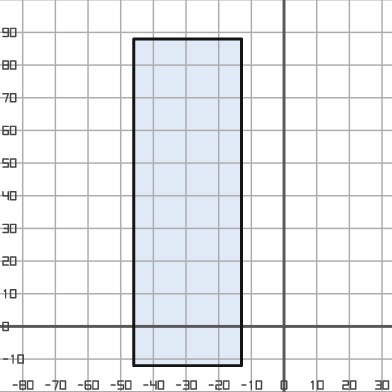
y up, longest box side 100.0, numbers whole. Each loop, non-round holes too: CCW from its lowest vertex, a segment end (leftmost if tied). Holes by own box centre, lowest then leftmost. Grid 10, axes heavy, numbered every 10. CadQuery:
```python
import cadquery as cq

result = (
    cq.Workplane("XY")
    .moveTo(-46.0, -12.0)
    .lineTo(-13.0, -12.0)
    .lineTo(-13.0, 88.0)
    .lineTo(-46.0, 88.0)
    .close()
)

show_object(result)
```